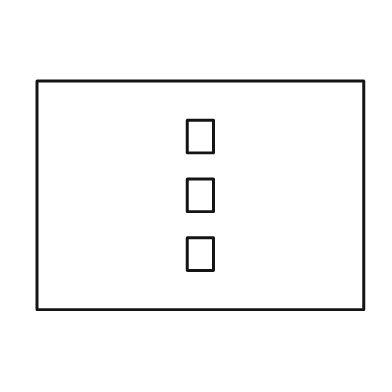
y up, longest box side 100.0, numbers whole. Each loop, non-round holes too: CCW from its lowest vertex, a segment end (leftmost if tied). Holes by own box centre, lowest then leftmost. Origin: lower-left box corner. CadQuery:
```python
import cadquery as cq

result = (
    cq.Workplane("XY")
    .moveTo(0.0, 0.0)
    .lineTo(100.0, 0.0)
    .lineTo(100.0, 70.0)
    .lineTo(0.0, 70.0)
    .close()
    .moveTo(46.0, 12.0)
    .lineTo(54.0, 12.0)
    .lineTo(54.0, 22.0)
    .lineTo(46.0, 22.0)
    .close()
    .moveTo(46.0, 30.0)
    .lineTo(54.0, 30.0)
    .lineTo(54.0, 40.0)
    .lineTo(46.0, 40.0)
    .close()
    .moveTo(46.0, 48.0)
    .lineTo(54.0, 48.0)
    .lineTo(54.0, 58.0)
    .lineTo(46.0, 58.0)
    .close()
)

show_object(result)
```